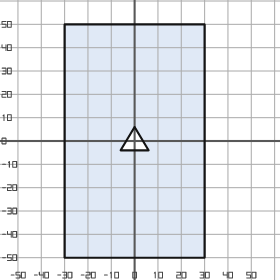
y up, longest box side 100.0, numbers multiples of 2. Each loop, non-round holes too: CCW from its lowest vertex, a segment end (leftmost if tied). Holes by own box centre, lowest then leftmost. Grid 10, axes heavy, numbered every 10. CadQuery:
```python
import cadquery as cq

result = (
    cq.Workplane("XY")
    .moveTo(-30.0, -50.0)
    .lineTo(30.0, -50.0)
    .lineTo(30.0, 50.0)
    .lineTo(-30.0, 50.0)
    .close()
    .moveTo(-6.0, -4.0)
    .lineTo(6.0, -4.0)
    .lineTo(0.0, 6.0)
    .close()
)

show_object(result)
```